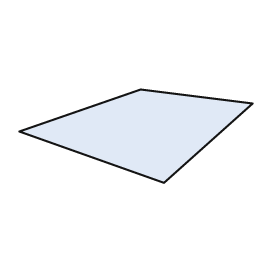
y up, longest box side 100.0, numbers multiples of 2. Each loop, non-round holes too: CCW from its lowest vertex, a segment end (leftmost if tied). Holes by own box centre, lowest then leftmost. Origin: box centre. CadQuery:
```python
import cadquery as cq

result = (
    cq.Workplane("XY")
    .moveTo(12.0, -20.0)
    .lineTo(50.0, 14.0)
    .lineTo(2.0, 20.0)
    .lineTo(-50.0, 2.0)
    .close()
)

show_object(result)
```